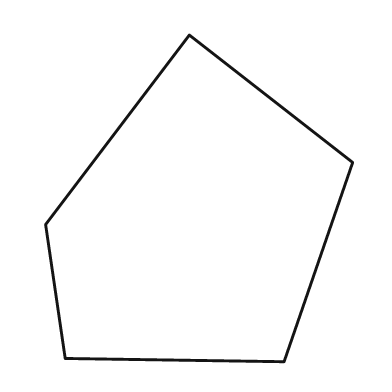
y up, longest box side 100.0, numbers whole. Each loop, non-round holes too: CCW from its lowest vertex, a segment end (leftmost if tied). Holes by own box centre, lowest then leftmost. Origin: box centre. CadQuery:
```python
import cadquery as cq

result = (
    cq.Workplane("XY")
    .moveTo(26.0, -50.0)
    .lineTo(47.0, 11.0)
    .lineTo(-3.0, 50.0)
    .lineTo(-47.0, -8.0)
    .lineTo(-41.0, -49.0)
    .close()
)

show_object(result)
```